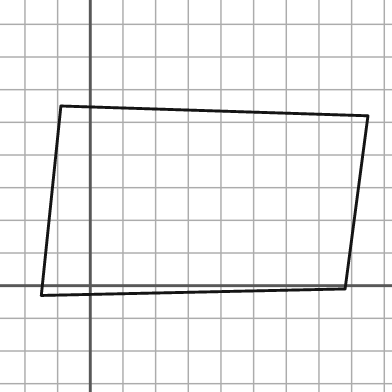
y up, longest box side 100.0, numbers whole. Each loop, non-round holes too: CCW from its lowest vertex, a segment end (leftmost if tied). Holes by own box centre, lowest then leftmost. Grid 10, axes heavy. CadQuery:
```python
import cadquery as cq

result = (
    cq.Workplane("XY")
    .moveTo(-15.0, -3.0)
    .lineTo(78.0, -1.0)
    .lineTo(85.0, 52.0)
    .lineTo(-9.0, 55.0)
    .close()
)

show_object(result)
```